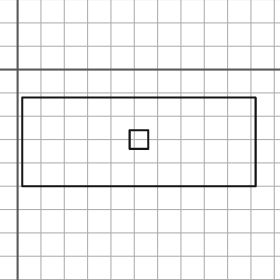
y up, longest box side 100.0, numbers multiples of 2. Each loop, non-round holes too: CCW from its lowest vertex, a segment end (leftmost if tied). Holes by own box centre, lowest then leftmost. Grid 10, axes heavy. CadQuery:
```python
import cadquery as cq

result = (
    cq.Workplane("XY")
    .moveTo(2.0, -50.0)
    .lineTo(102.0, -50.0)
    .lineTo(102.0, -12.0)
    .lineTo(2.0, -12.0)
    .close()
    .moveTo(48.0, -34.0)
    .lineTo(56.0, -34.0)
    .lineTo(56.0, -26.0)
    .lineTo(48.0, -26.0)
    .close()
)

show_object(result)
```